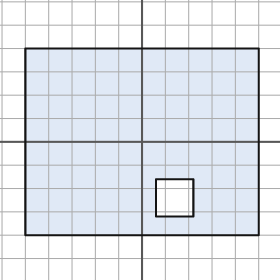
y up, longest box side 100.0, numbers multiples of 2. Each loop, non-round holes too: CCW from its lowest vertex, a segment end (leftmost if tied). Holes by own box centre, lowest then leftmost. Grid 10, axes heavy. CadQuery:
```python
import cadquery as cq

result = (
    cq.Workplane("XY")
    .moveTo(-50.0, -40.0)
    .lineTo(50.0, -40.0)
    .lineTo(50.0, 40.0)
    .lineTo(-50.0, 40.0)
    .close()
    .moveTo(6.0, -32.0)
    .lineTo(22.0, -32.0)
    .lineTo(22.0, -16.0)
    .lineTo(6.0, -16.0)
    .close()
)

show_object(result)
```